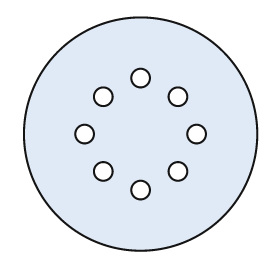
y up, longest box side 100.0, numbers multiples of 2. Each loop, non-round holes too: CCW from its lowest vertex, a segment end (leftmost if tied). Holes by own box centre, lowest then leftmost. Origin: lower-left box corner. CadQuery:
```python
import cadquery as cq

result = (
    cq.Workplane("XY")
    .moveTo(50.0, 50.0)
    .circle(50.0)
    .moveTo(50.0, 26.0)
    .circle(4.0)
    .moveTo(34.0, 34.0)
    .circle(4.0)
    .moveTo(66.0, 34.0)
    .circle(4.0)
    .moveTo(26.0, 50.0)
    .circle(4.0)
    .moveTo(74.0, 50.0)
    .circle(4.0)
    .moveTo(34.0, 66.0)
    .circle(4.0)
    .moveTo(66.0, 66.0)
    .circle(4.0)
    .moveTo(50.0, 74.0)
    .circle(4.0)
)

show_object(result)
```